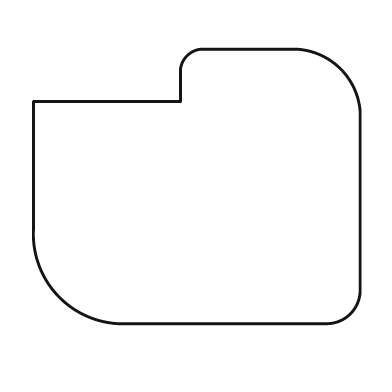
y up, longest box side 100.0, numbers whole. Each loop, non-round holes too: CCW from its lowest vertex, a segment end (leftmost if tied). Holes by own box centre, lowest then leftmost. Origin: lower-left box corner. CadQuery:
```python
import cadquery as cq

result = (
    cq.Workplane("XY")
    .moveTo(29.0, 0.0)
    .lineTo(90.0, 0.0)
    .threePointArc((97.0, 3.0), (100.0, 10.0))
    .lineTo(100.0, 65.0)
    .threePointArc((94.0, 78.0), (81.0, 84.0))
    .lineTo(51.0, 84.0)
    .threePointArc((47.0, 82.0), (45.0, 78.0))
    .lineTo(45.0, 68.0)
    .lineTo(0.0, 68.0)
    .lineTo(0.0, 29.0)
    .threePointArc((8.0, 8.0), (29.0, 0.0))
    .close()
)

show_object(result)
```